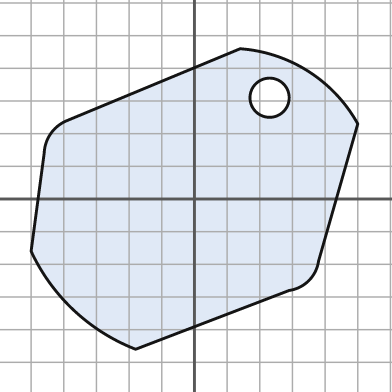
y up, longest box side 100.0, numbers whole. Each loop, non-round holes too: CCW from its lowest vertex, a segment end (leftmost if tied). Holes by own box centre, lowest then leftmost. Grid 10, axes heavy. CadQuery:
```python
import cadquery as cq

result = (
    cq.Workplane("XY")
    .moveTo(-18.0, -46.0)
    .lineTo(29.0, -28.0)
    .threePointArc((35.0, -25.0), (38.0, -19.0))
    .lineTo(50.0, 23.0)
    .threePointArc((35.0, 39.0), (14.0, 46.0))
    .lineTo(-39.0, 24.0)
    .threePointArc((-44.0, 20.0), (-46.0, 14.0))
    .lineTo(-50.0, -16.0)
    .threePointArc((-37.0, -34.0), (-18.0, -46.0))
    .close()
    .moveTo(23.0, 31.0)
    .circle(6.0)
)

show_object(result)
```